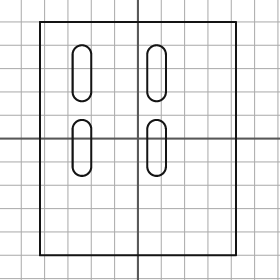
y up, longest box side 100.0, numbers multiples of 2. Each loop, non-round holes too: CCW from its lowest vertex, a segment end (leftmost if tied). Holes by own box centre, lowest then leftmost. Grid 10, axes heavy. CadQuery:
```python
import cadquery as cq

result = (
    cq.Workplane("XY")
    .moveTo(-42.0, -50.0)
    .lineTo(42.0, -50.0)
    .lineTo(42.0, 50.0)
    .lineTo(-42.0, 50.0)
    .close()
    .moveTo(-28.0, -12.0)
    .threePointArc((-24.0, -16.0), (-20.0, -12.0))
    .lineTo(-20.0, 4.0)
    .threePointArc((-24.0, 8.0), (-28.0, 4.0))
    .close()
    .moveTo(4.0, -12.0)
    .threePointArc((8.0, -16.0), (12.0, -12.0))
    .lineTo(12.0, 4.0)
    .threePointArc((8.0, 8.0), (4.0, 4.0))
    .close()
    .moveTo(-28.0, 20.0)
    .threePointArc((-24.0, 16.0), (-20.0, 20.0))
    .lineTo(-20.0, 36.0)
    .threePointArc((-24.0, 40.0), (-28.0, 36.0))
    .close()
    .moveTo(4.0, 20.0)
    .threePointArc((8.0, 16.0), (12.0, 20.0))
    .lineTo(12.0, 36.0)
    .threePointArc((8.0, 40.0), (4.0, 36.0))
    .close()
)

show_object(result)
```